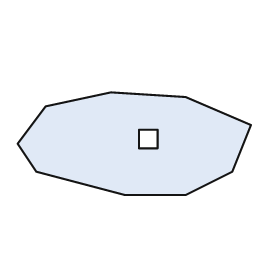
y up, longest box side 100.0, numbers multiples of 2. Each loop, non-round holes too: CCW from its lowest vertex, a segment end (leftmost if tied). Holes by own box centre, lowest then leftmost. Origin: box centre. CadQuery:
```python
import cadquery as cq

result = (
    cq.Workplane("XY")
    .moveTo(-4.0, -22.0)
    .lineTo(22.0, -22.0)
    .lineTo(42.0, -12.0)
    .lineTo(50.0, 8.0)
    .lineTo(22.0, 20.0)
    .lineTo(-10.0, 22.0)
    .lineTo(-38.0, 16.0)
    .lineTo(-50.0, 0.0)
    .lineTo(-42.0, -12.0)
    .close()
    .moveTo(2.0, -2.0)
    .lineTo(10.0, -2.0)
    .lineTo(10.0, 6.0)
    .lineTo(2.0, 6.0)
    .close()
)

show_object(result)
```